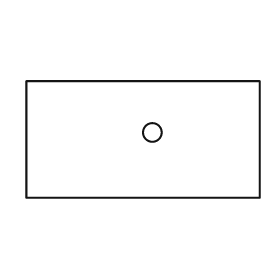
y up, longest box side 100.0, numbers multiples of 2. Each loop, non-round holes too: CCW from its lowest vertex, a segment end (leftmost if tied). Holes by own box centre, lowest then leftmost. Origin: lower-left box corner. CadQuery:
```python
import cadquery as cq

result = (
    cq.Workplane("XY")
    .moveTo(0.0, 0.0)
    .lineTo(100.0, 0.0)
    .lineTo(100.0, 50.0)
    .lineTo(0.0, 50.0)
    .close()
    .moveTo(54.0, 28.0)
    .circle(4.0)
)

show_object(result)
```